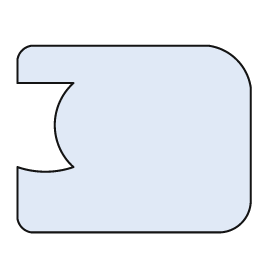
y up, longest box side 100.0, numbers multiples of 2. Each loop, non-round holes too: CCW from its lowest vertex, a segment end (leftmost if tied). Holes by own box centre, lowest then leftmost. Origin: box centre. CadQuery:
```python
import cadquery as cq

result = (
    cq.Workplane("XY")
    .moveTo(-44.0, -40.0)
    .lineTo(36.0, -40.0)
    .threePointArc((46.0, -36.0), (50.0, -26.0))
    .lineTo(50.0, 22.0)
    .threePointArc((44.0, 34.0), (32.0, 40.0))
    .lineTo(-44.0, 40.0)
    .threePointArc((-48.0, 38.0), (-50.0, 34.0))
    .lineTo(-50.0, 24.0)
    .lineTo(-26.0, 24.0)
    .threePointArc((-34.0, 6.0), (-26.0, -12.0))
    .threePointArc((-38.0, -14.0), (-50.0, -12.0))
    .lineTo(-50.0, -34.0)
    .threePointArc((-48.0, -38.0), (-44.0, -40.0))
    .close()
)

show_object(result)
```